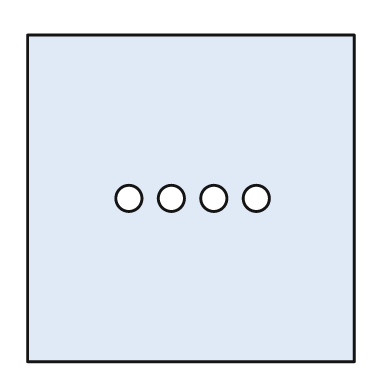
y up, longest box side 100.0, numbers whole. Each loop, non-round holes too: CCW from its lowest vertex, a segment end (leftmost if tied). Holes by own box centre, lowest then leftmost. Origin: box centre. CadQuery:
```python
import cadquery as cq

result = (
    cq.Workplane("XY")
    .moveTo(-50.0, -50.0)
    .lineTo(50.0, -50.0)
    .lineTo(50.0, 50.0)
    .lineTo(-50.0, 50.0)
    .close()
    .moveTo(-19.0, 0.0)
    .circle(4.0)
    .moveTo(-6.0, 0.0)
    .circle(4.0)
    .moveTo(7.0, 0.0)
    .circle(4.0)
    .moveTo(20.0, 0.0)
    .circle(4.0)
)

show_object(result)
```